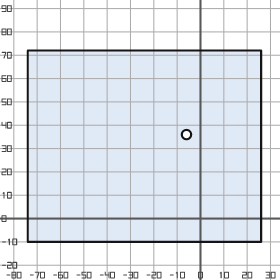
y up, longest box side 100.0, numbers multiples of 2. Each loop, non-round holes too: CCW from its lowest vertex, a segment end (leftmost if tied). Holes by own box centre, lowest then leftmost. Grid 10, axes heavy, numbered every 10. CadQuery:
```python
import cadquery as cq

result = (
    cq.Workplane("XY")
    .moveTo(-74.0, -10.0)
    .lineTo(26.0, -10.0)
    .lineTo(26.0, 72.0)
    .lineTo(-74.0, 72.0)
    .close()
    .moveTo(-6.0, 36.0)
    .circle(2.0)
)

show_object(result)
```